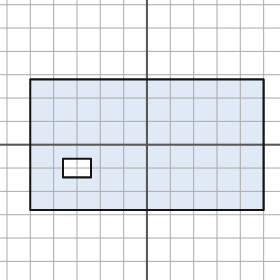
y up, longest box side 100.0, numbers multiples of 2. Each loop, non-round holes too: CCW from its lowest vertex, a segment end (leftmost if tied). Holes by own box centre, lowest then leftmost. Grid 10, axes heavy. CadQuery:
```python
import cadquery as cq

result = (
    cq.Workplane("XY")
    .moveTo(-50.0, -28.0)
    .lineTo(50.0, -28.0)
    .lineTo(50.0, 28.0)
    .lineTo(-50.0, 28.0)
    .close()
    .moveTo(-36.0, -14.0)
    .lineTo(-24.0, -14.0)
    .lineTo(-24.0, -6.0)
    .lineTo(-36.0, -6.0)
    .close()
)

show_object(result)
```